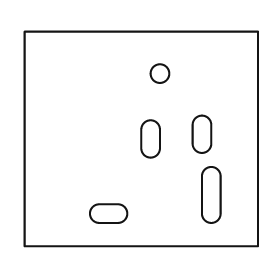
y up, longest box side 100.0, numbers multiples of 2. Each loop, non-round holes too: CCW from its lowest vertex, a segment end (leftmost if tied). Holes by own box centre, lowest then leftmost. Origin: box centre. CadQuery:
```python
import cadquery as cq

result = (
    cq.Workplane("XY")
    .moveTo(-50.0, -46.0)
    .lineTo(50.0, -46.0)
    .lineTo(50.0, 46.0)
    .lineTo(-50.0, 46.0)
    .close()
    .moveTo(-18.0, -36.0)
    .lineTo(-10.0, -36.0)
    .threePointArc((-6.0, -32.0), (-10.0, -28.0))
    .lineTo(-18.0, -28.0)
    .threePointArc((-22.0, -32.0), (-18.0, -36.0))
    .close()
    .moveTo(26.0, -32.0)
    .threePointArc((30.0, -36.0), (34.0, -32.0))
    .lineTo(34.0, -16.0)
    .threePointArc((30.0, -12.0), (26.0, -16.0))
    .close()
    .moveTo(0.0, -4.0)
    .threePointArc((4.0, -8.0), (8.0, -4.0))
    .lineTo(8.0, 4.0)
    .threePointArc((4.0, 8.0), (0.0, 4.0))
    .close()
    .moveTo(22.0, -2.0)
    .threePointArc((26.0, -6.0), (30.0, -2.0))
    .lineTo(30.0, 6.0)
    .threePointArc((26.0, 10.0), (22.0, 6.0))
    .close()
    .moveTo(8.0, 28.0)
    .circle(4.0)
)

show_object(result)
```